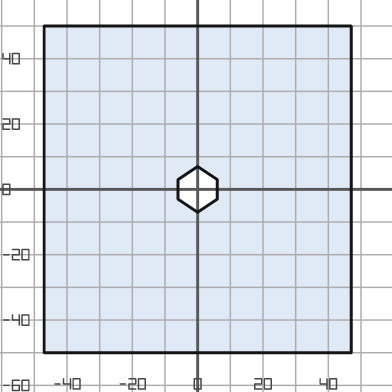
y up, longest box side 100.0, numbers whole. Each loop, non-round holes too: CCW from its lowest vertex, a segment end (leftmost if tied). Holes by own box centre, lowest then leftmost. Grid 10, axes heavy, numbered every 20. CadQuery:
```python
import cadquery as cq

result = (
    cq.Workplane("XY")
    .moveTo(-47.0, -50.0)
    .lineTo(47.0, -50.0)
    .lineTo(47.0, 50.0)
    .lineTo(-47.0, 50.0)
    .close()
    .moveTo(0.0, -7.0)
    .lineTo(6.0, -3.0)
    .lineTo(6.0, 3.0)
    .lineTo(0.0, 7.0)
    .lineTo(-6.0, 3.0)
    .lineTo(-6.0, -3.0)
    .close()
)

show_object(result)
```